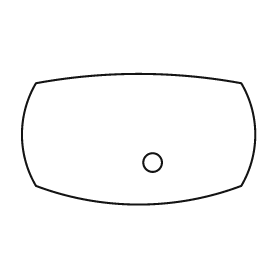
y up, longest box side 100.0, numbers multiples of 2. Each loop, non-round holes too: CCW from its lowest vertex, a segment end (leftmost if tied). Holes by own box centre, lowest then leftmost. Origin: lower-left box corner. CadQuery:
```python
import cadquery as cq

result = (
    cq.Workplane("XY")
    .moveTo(6.0, 8.0)
    .threePointArc((50.0, 0.0), (94.0, 8.0))
    .threePointArc((100.0, 30.0), (94.0, 52.0))
    .threePointArc((50.0, 56.0), (6.0, 52.0))
    .threePointArc((0.0, 30.0), (6.0, 8.0))
    .close()
    .moveTo(56.0, 18.0)
    .circle(4.0)
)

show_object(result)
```